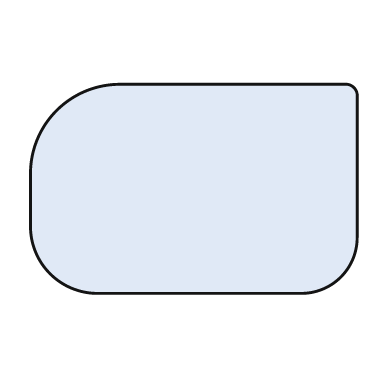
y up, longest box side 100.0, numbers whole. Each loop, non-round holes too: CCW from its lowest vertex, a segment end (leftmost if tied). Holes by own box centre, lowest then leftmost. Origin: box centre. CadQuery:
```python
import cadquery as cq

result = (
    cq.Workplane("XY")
    .moveTo(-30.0, -32.0)
    .lineTo(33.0, -32.0)
    .threePointArc((45.0, -27.0), (50.0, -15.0))
    .lineTo(50.0, 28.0)
    .threePointArc((49.0, 31.0), (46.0, 32.0))
    .lineTo(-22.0, 32.0)
    .threePointArc((-42.0, 24.0), (-50.0, 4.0))
    .lineTo(-50.0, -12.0)
    .threePointArc((-44.0, -26.0), (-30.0, -32.0))
    .close()
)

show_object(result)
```